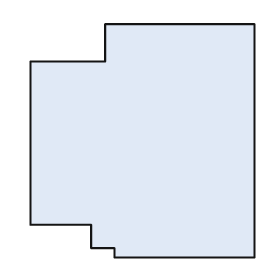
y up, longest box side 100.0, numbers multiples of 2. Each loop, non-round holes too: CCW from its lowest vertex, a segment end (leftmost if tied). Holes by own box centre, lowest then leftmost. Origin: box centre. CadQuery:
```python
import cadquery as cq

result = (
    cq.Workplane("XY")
    .moveTo(-12.0, -50.0)
    .lineTo(48.0, -50.0)
    .lineTo(48.0, 50.0)
    .lineTo(-16.0, 50.0)
    .lineTo(-16.0, 34.0)
    .lineTo(-48.0, 34.0)
    .lineTo(-48.0, -36.0)
    .lineTo(-22.0, -36.0)
    .lineTo(-22.0, -46.0)
    .lineTo(-12.0, -46.0)
    .close()
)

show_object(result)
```